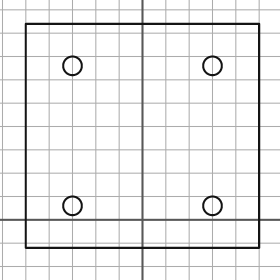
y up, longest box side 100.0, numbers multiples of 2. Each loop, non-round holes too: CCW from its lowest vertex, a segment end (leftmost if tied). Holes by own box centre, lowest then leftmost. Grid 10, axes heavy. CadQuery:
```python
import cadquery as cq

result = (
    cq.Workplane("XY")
    .moveTo(-50.0, -12.0)
    .lineTo(50.0, -12.0)
    .lineTo(50.0, 84.0)
    .lineTo(-50.0, 84.0)
    .close()
    .moveTo(-30.0, 6.0)
    .circle(4.0)
    .moveTo(30.0, 6.0)
    .circle(4.0)
    .moveTo(-30.0, 66.0)
    .circle(4.0)
    .moveTo(30.0, 66.0)
    .circle(4.0)
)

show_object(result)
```